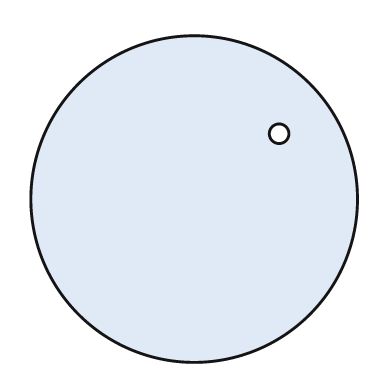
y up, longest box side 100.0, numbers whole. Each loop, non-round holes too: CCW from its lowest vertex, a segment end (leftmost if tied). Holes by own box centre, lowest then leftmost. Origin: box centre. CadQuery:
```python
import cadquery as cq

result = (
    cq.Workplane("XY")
    .moveTo(0.0, 0.0)
    .circle(50.0)
    .moveTo(26.0, 20.0)
    .circle(3.0)
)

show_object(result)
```